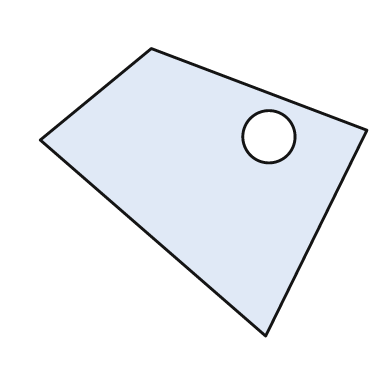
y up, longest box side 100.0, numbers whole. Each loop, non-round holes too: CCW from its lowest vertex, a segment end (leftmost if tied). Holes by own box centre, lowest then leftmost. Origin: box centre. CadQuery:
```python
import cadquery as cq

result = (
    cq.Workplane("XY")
    .moveTo(19.0, -44.0)
    .lineTo(50.0, 19.0)
    .lineTo(-16.0, 44.0)
    .lineTo(-50.0, 16.0)
    .close()
    .moveTo(20.0, 17.0)
    .circle(8.0)
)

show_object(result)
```